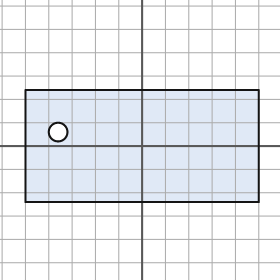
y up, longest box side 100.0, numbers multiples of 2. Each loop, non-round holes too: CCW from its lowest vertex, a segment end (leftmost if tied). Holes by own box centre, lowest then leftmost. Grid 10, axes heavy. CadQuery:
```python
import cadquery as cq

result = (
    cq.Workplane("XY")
    .moveTo(-50.0, -24.0)
    .lineTo(50.0, -24.0)
    .lineTo(50.0, 24.0)
    .lineTo(-50.0, 24.0)
    .close()
    .moveTo(-36.0, 6.0)
    .circle(4.0)
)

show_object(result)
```